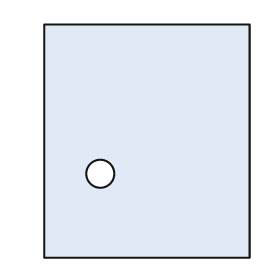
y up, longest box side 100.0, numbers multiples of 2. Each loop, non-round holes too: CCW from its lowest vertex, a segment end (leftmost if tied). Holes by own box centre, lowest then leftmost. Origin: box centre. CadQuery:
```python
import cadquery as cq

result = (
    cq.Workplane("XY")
    .moveTo(-44.0, -50.0)
    .lineTo(44.0, -50.0)
    .lineTo(44.0, 50.0)
    .lineTo(-44.0, 50.0)
    .close()
    .moveTo(-20.0, -14.0)
    .circle(6.0)
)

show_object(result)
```